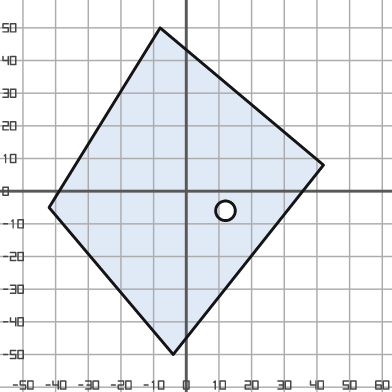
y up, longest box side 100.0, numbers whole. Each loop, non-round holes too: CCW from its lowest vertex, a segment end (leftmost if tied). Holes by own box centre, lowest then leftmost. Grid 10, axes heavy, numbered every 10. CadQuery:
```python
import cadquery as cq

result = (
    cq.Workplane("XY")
    .moveTo(-4.0, -50.0)
    .lineTo(42.0, 8.0)
    .lineTo(-8.0, 50.0)
    .lineTo(-42.0, -5.0)
    .close()
    .moveTo(12.0, -6.0)
    .circle(3.0)
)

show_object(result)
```